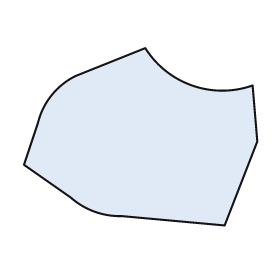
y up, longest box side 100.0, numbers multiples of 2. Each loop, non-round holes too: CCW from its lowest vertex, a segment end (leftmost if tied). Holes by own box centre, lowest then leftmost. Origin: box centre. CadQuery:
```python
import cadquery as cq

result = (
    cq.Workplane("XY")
    .moveTo(36.0, -38.0)
    .lineTo(50.0, -2.0)
    .lineTo(48.0, 22.0)
    .threePointArc((22.0, 22.0), (2.0, 38.0))
    .lineTo(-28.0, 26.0)
    .threePointArc((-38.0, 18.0), (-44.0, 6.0))
    .lineTo(-50.0, -12.0)
    .lineTo(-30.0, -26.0)
    .threePointArc((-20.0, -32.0), (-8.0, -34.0))
    .close()
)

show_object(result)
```